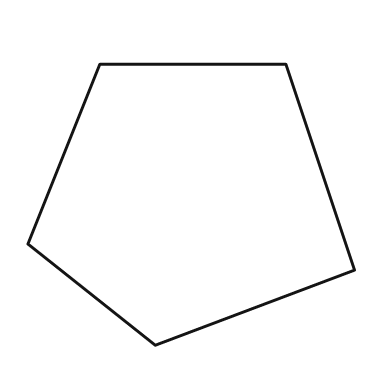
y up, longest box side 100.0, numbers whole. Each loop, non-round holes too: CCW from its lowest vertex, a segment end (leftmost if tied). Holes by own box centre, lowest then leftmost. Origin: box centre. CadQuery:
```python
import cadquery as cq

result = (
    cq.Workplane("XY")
    .moveTo(-11.0, -43.0)
    .lineTo(50.0, -20.0)
    .lineTo(29.0, 43.0)
    .lineTo(-28.0, 43.0)
    .lineTo(-50.0, -12.0)
    .close()
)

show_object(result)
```